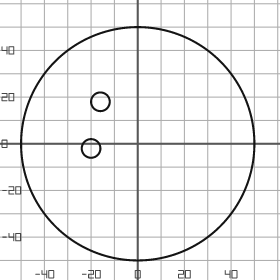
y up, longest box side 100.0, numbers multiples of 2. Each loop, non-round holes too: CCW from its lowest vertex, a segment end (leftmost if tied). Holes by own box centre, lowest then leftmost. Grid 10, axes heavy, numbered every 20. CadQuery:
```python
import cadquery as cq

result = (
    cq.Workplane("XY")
    .moveTo(0.0, 0.0)
    .circle(50.0)
    .moveTo(-20.0, -2.0)
    .circle(4.0)
    .moveTo(-16.0, 18.0)
    .circle(4.0)
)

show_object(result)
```